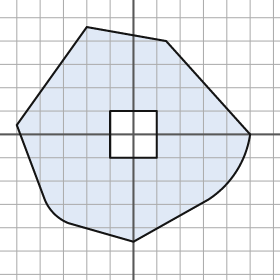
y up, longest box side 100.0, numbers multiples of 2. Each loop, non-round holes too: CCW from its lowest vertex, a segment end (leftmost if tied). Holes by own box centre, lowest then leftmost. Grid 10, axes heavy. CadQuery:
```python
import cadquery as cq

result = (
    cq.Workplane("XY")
    .moveTo(0.0, -46.0)
    .lineTo(32.0, -28.0)
    .threePointArc((44.0, -16.0), (50.0, 0.0))
    .lineTo(14.0, 40.0)
    .lineTo(-20.0, 46.0)
    .lineTo(-50.0, 4.0)
    .lineTo(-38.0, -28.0)
    .threePointArc((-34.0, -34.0), (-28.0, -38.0))
    .close()
    .moveTo(-10.0, -10.0)
    .lineTo(10.0, -10.0)
    .lineTo(10.0, 10.0)
    .lineTo(-10.0, 10.0)
    .close()
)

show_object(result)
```